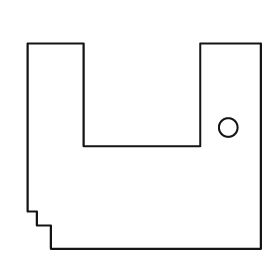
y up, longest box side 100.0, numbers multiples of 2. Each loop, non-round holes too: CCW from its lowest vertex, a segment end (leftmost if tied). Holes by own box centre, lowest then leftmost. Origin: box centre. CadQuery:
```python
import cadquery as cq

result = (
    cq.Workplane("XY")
    .moveTo(-40.0, -44.0)
    .lineTo(50.0, -44.0)
    .lineTo(50.0, 44.0)
    .lineTo(24.0, 44.0)
    .lineTo(24.0, 0.0)
    .lineTo(-26.0, 0.0)
    .lineTo(-26.0, 44.0)
    .lineTo(-50.0, 44.0)
    .lineTo(-50.0, -28.0)
    .lineTo(-46.0, -28.0)
    .lineTo(-46.0, -34.0)
    .lineTo(-40.0, -34.0)
    .close()
    .moveTo(36.0, 8.0)
    .circle(4.0)
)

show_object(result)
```